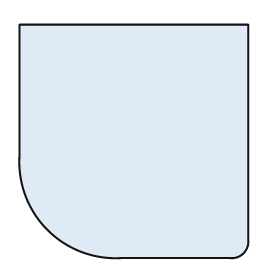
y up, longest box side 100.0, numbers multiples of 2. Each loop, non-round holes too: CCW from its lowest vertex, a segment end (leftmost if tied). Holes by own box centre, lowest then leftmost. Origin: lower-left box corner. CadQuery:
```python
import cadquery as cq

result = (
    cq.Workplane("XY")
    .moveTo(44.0, 0.0)
    .lineTo(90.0, 0.0)
    .threePointArc((96.0, 2.0), (98.0, 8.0))
    .lineTo(98.0, 100.0)
    .lineTo(0.0, 100.0)
    .lineTo(0.0, 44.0)
    .threePointArc((12.0, 12.0), (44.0, 0.0))
    .close()
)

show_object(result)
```